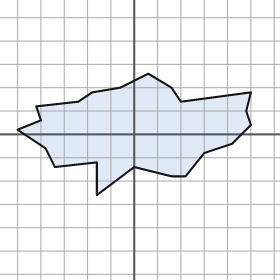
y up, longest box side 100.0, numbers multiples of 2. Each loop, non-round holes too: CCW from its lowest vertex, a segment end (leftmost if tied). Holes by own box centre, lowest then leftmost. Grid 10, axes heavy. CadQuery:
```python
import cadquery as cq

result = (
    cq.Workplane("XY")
    .moveTo(-16.0, -26.0)
    .lineTo(0.0, -14.0)
    .lineTo(16.0, -18.0)
    .lineTo(22.0, -18.0)
    .lineTo(30.0, -8.0)
    .lineTo(42.0, -4.0)
    .lineTo(50.0, 4.0)
    .lineTo(48.0, 10.0)
    .lineTo(50.0, 18.0)
    .lineTo(20.0, 14.0)
    .lineTo(16.0, 20.0)
    .lineTo(6.0, 26.0)
    .lineTo(-6.0, 20.0)
    .lineTo(-18.0, 18.0)
    .lineTo(-24.0, 14.0)
    .lineTo(-42.0, 12.0)
    .lineTo(-40.0, 6.0)
    .lineTo(-50.0, 2.0)
    .lineTo(-38.0, -6.0)
    .lineTo(-34.0, -14.0)
    .lineTo(-16.0, -12.0)
    .close()
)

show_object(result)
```